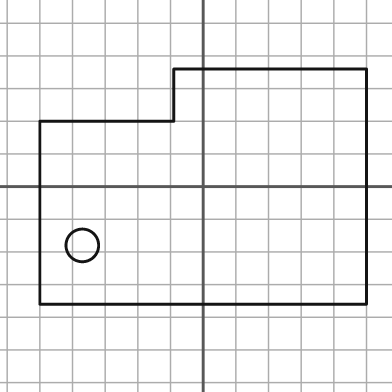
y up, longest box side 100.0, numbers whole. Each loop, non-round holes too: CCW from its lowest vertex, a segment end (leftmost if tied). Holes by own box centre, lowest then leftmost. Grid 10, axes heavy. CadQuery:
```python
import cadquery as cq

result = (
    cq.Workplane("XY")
    .moveTo(-50.0, -36.0)
    .lineTo(50.0, -36.0)
    .lineTo(50.0, 36.0)
    .lineTo(-9.0, 36.0)
    .lineTo(-9.0, 20.0)
    .lineTo(-50.0, 20.0)
    .close()
    .moveTo(-37.0, -18.0)
    .circle(5.0)
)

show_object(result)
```